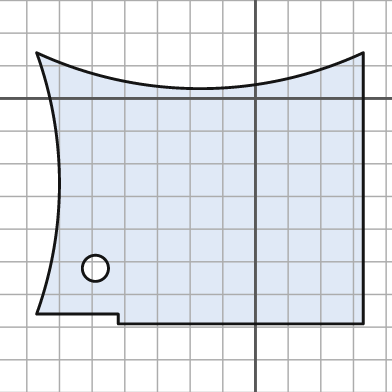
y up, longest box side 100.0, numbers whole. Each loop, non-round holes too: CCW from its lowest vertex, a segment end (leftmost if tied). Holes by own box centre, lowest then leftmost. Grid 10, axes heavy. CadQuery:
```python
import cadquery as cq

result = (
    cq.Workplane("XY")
    .moveTo(-42.0, -69.0)
    .lineTo(33.0, -69.0)
    .lineTo(33.0, 14.0)
    .threePointArc((-17.0, 3.0), (-67.0, 14.0))
    .threePointArc((-60.0, -26.0), (-67.0, -66.0))
    .lineTo(-42.0, -66.0)
    .close()
    .moveTo(-49.0, -52.0)
    .circle(4.0)
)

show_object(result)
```